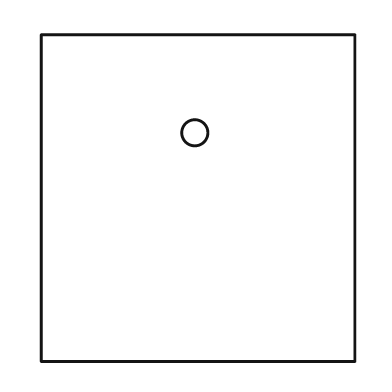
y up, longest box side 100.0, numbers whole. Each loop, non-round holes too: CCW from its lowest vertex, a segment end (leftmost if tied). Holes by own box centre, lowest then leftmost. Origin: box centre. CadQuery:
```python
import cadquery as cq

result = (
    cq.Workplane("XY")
    .moveTo(-48.0, -50.0)
    .lineTo(48.0, -50.0)
    .lineTo(48.0, 50.0)
    .lineTo(-48.0, 50.0)
    .close()
    .moveTo(-1.0, 20.0)
    .circle(4.0)
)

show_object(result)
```